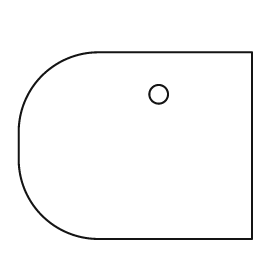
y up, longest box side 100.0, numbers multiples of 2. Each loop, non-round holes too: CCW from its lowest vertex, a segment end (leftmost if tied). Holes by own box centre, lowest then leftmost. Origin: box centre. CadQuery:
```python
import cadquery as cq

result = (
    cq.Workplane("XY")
    .moveTo(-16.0, -40.0)
    .lineTo(50.0, -40.0)
    .lineTo(50.0, 40.0)
    .lineTo(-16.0, 40.0)
    .threePointArc((-40.0, 30.0), (-50.0, 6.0))
    .lineTo(-50.0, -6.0)
    .threePointArc((-40.0, -30.0), (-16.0, -40.0))
    .close()
    .moveTo(10.0, 22.0)
    .circle(4.0)
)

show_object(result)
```